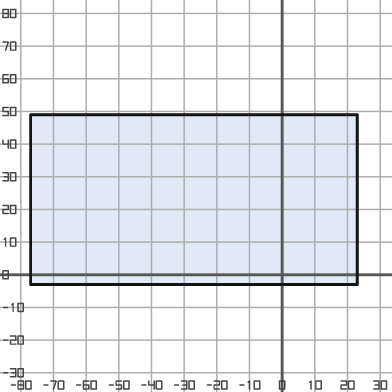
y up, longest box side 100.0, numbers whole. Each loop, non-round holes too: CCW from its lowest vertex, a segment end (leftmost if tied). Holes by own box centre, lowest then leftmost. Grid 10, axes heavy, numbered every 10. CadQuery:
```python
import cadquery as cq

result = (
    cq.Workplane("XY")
    .moveTo(-77.0, -3.0)
    .lineTo(23.0, -3.0)
    .lineTo(23.0, 49.0)
    .lineTo(-77.0, 49.0)
    .close()
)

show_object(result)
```